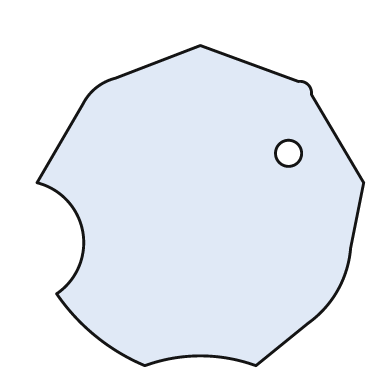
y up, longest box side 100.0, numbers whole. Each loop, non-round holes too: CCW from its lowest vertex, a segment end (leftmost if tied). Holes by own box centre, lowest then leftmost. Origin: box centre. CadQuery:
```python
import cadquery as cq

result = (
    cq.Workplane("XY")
    .moveTo(-17.0, -49.0)
    .threePointArc((0.0, -46.0), (17.0, -49.0))
    .lineTo(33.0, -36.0)
    .threePointArc((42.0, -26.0), (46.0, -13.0))
    .lineTo(50.0, 7.0)
    .lineTo(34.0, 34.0)
    .threePointArc((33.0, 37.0), (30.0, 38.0))
    .lineTo(0.0, 49.0)
    .lineTo(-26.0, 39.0)
    .threePointArc((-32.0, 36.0), (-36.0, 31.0))
    .lineTo(-50.0, 7.0)
    .threePointArc((-36.0, -8.0), (-44.0, -27.0))
    .threePointArc((-32.0, -40.0), (-17.0, -49.0))
    .close()
    .moveTo(27.0, 16.0)
    .circle(4.0)
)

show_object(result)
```